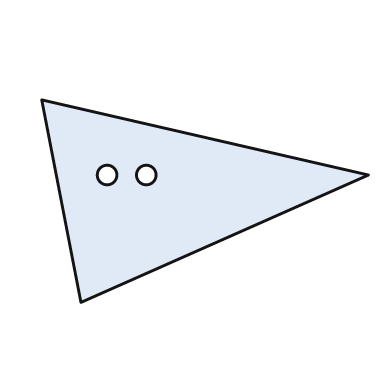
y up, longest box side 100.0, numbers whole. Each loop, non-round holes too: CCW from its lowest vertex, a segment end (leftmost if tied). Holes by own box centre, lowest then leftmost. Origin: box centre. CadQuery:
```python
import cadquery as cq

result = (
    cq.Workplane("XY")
    .moveTo(-38.0, -31.0)
    .lineTo(50.0, 8.0)
    .lineTo(-50.0, 31.0)
    .close()
    .moveTo(-30.0, 8.0)
    .circle(3.0)
    .moveTo(-18.0, 8.0)
    .circle(3.0)
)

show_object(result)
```